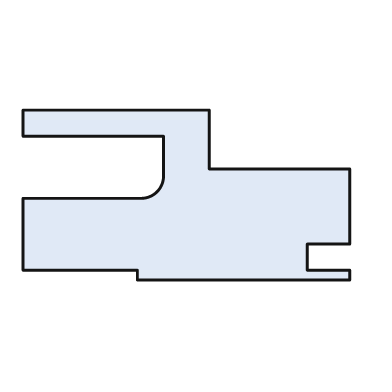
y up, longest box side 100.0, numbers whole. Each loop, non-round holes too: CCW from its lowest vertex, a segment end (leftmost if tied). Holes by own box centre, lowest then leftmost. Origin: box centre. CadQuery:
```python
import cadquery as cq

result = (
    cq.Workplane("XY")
    .moveTo(-15.0, -26.0)
    .lineTo(50.0, -26.0)
    .lineTo(50.0, -23.0)
    .lineTo(37.0, -23.0)
    .lineTo(37.0, -15.0)
    .lineTo(50.0, -15.0)
    .lineTo(50.0, 8.0)
    .lineTo(7.0, 8.0)
    .lineTo(7.0, 26.0)
    .lineTo(-50.0, 26.0)
    .lineTo(-50.0, 18.0)
    .lineTo(-7.0, 18.0)
    .lineTo(-7.0, 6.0)
    .threePointArc((-9.0, 1.0), (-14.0, -1.0))
    .lineTo(-50.0, -1.0)
    .lineTo(-50.0, -23.0)
    .lineTo(-15.0, -23.0)
    .close()
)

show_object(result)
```